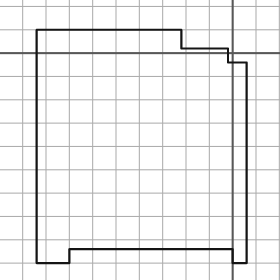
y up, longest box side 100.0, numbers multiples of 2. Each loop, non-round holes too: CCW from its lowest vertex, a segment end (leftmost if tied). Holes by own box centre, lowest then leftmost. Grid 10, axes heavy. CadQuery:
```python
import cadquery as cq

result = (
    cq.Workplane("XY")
    .moveTo(-84.0, -90.0)
    .lineTo(-70.0, -90.0)
    .lineTo(-70.0, -84.0)
    .lineTo(0.0, -84.0)
    .lineTo(0.0, -90.0)
    .lineTo(6.0, -90.0)
    .lineTo(6.0, -4.0)
    .lineTo(-2.0, -4.0)
    .lineTo(-2.0, 2.0)
    .lineTo(-22.0, 2.0)
    .lineTo(-22.0, 10.0)
    .lineTo(-84.0, 10.0)
    .close()
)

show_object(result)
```